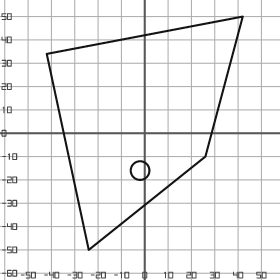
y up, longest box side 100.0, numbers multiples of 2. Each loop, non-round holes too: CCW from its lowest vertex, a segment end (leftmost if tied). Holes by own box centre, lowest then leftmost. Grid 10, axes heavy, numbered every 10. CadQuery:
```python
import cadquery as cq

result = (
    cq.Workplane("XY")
    .moveTo(-24.0, -50.0)
    .lineTo(26.0, -10.0)
    .lineTo(42.0, 50.0)
    .lineTo(-42.0, 34.0)
    .close()
    .moveTo(-2.0, -16.0)
    .circle(4.0)
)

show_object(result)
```